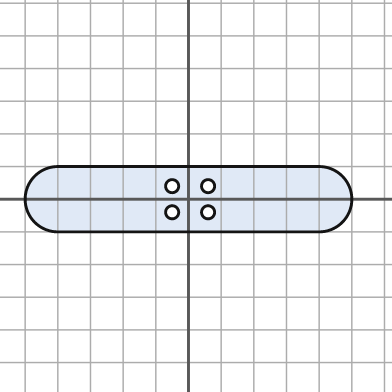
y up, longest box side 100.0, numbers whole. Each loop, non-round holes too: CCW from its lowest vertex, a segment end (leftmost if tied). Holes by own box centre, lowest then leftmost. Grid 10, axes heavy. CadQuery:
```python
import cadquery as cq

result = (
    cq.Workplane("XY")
    .moveTo(-40.0, -10.0)
    .lineTo(40.0, -10.0)
    .threePointArc((50.0, 0.0), (40.0, 10.0))
    .lineTo(-40.0, 10.0)
    .threePointArc((-50.0, 0.0), (-40.0, -10.0))
    .close()
    .moveTo(-5.0, -4.0)
    .circle(2.0)
    .moveTo(6.0, -4.0)
    .circle(2.0)
    .moveTo(-5.0, 4.0)
    .circle(2.0)
    .moveTo(6.0, 4.0)
    .circle(2.0)
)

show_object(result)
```